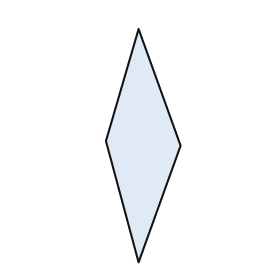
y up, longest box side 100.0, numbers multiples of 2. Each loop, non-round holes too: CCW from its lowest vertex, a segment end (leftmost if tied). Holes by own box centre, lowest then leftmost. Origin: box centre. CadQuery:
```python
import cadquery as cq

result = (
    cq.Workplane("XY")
    .moveTo(-2.0, -50.0)
    .lineTo(16.0, 0.0)
    .lineTo(-2.0, 50.0)
    .lineTo(-16.0, 2.0)
    .close()
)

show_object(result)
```